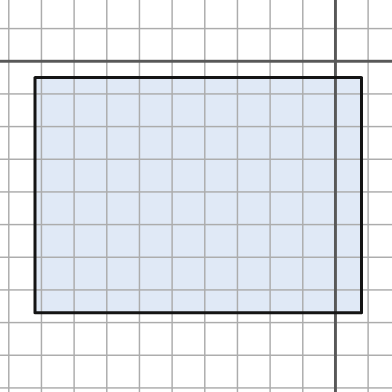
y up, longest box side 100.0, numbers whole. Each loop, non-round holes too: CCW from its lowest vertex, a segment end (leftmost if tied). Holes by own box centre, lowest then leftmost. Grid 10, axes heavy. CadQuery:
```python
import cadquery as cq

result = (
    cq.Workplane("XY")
    .moveTo(-92.0, -77.0)
    .lineTo(8.0, -77.0)
    .lineTo(8.0, -5.0)
    .lineTo(-92.0, -5.0)
    .close()
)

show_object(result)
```